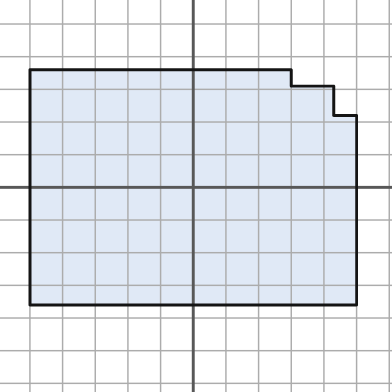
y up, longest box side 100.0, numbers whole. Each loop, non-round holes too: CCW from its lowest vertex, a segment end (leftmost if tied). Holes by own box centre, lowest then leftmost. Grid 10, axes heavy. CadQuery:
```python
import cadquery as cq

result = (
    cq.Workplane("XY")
    .moveTo(-50.0, -36.0)
    .lineTo(50.0, -36.0)
    .lineTo(50.0, 22.0)
    .lineTo(43.0, 22.0)
    .lineTo(43.0, 31.0)
    .lineTo(30.0, 31.0)
    .lineTo(30.0, 36.0)
    .lineTo(-50.0, 36.0)
    .close()
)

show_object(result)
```